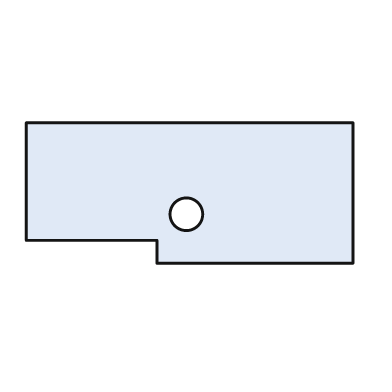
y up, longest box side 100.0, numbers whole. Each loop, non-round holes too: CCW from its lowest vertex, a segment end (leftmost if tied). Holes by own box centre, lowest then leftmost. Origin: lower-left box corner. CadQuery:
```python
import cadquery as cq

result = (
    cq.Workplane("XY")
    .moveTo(40.0, 0.0)
    .lineTo(100.0, 0.0)
    .lineTo(100.0, 43.0)
    .lineTo(0.0, 43.0)
    .lineTo(0.0, 7.0)
    .lineTo(40.0, 7.0)
    .close()
    .moveTo(49.0, 15.0)
    .circle(5.0)
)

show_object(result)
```